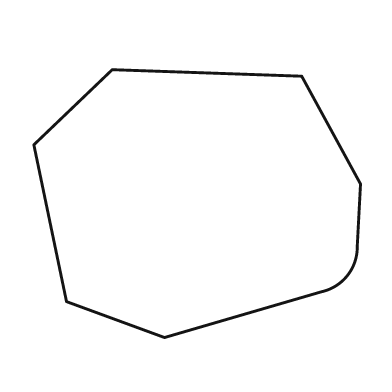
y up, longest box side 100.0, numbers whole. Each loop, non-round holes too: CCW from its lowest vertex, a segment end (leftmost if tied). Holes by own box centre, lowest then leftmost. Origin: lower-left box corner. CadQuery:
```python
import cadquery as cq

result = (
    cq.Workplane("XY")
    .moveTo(40.0, 0.0)
    .lineTo(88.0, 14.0)
    .threePointArc((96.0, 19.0), (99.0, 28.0))
    .lineTo(100.0, 47.0)
    .lineTo(82.0, 80.0)
    .lineTo(24.0, 82.0)
    .lineTo(0.0, 59.0)
    .lineTo(10.0, 11.0)
    .close()
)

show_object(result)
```